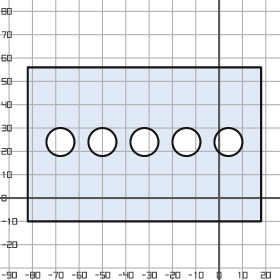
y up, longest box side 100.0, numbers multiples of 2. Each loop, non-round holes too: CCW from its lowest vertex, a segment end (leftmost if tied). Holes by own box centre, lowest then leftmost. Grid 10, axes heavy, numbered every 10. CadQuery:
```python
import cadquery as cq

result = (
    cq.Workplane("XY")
    .moveTo(-82.0, -10.0)
    .lineTo(18.0, -10.0)
    .lineTo(18.0, 56.0)
    .lineTo(-82.0, 56.0)
    .close()
    .moveTo(-68.0, 24.0)
    .circle(6.0)
    .moveTo(-50.0, 24.0)
    .circle(6.0)
    .moveTo(-32.0, 24.0)
    .circle(6.0)
    .moveTo(-14.0, 24.0)
    .circle(6.0)
    .moveTo(4.0, 24.0)
    .circle(6.0)
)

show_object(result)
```